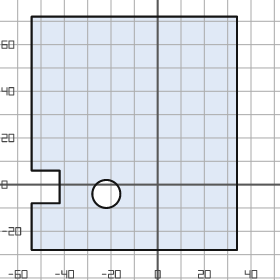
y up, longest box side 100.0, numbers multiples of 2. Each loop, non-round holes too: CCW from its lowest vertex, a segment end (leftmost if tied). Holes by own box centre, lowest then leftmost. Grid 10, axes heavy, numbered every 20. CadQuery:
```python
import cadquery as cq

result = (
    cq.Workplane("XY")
    .moveTo(-54.0, -28.0)
    .lineTo(34.0, -28.0)
    .lineTo(34.0, 72.0)
    .lineTo(-54.0, 72.0)
    .lineTo(-54.0, 6.0)
    .lineTo(-42.0, 6.0)
    .lineTo(-42.0, -8.0)
    .lineTo(-54.0, -8.0)
    .close()
    .moveTo(-22.0, -4.0)
    .circle(6.0)
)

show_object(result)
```